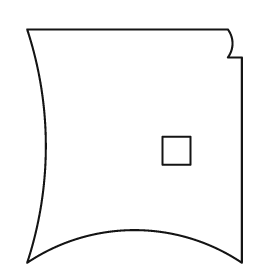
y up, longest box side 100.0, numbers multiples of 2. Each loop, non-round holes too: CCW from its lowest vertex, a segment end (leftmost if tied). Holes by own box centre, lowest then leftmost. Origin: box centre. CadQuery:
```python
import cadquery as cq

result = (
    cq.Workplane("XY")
    .moveTo(-46.0, -50.0)
    .threePointArc((0.0, -36.0), (46.0, -50.0))
    .lineTo(46.0, 38.0)
    .lineTo(40.0, 38.0)
    .threePointArc((42.0, 44.0), (40.0, 50.0))
    .lineTo(-46.0, 50.0)
    .threePointArc((-38.0, 0.0), (-46.0, -50.0))
    .close()
    .moveTo(12.0, -8.0)
    .lineTo(24.0, -8.0)
    .lineTo(24.0, 4.0)
    .lineTo(12.0, 4.0)
    .close()
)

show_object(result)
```